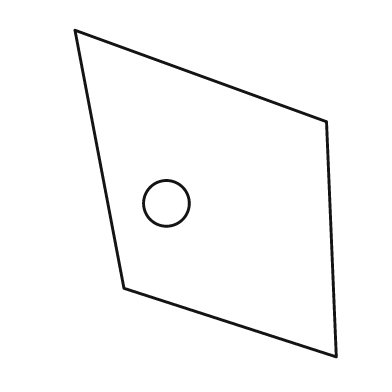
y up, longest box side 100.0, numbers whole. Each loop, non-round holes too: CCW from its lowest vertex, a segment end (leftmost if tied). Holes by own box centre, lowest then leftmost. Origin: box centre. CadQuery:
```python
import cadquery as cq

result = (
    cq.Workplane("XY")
    .moveTo(40.0, -50.0)
    .lineTo(37.0, 22.0)
    .lineTo(-40.0, 50.0)
    .lineTo(-25.0, -29.0)
    .close()
    .moveTo(-12.0, -3.0)
    .circle(7.0)
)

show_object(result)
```